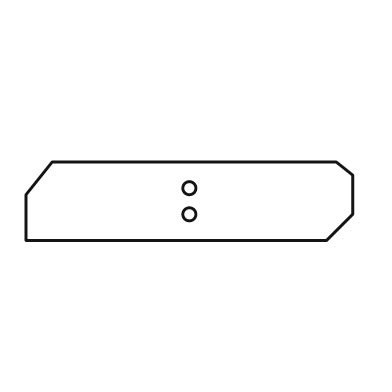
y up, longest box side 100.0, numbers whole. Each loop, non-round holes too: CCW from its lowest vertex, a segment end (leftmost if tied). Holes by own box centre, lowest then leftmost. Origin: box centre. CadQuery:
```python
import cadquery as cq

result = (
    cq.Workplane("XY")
    .moveTo(-50.0, -12.0)
    .lineTo(42.0, -12.0)
    .lineTo(50.0, -4.0)
    .lineTo(50.0, 8.0)
    .lineTo(45.0, 12.0)
    .lineTo(-42.0, 12.0)
    .lineTo(-50.0, 2.0)
    .close()
    .moveTo(0.0, -4.0)
    .circle(2.0)
    .moveTo(0.0, 4.0)
    .circle(2.0)
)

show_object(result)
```